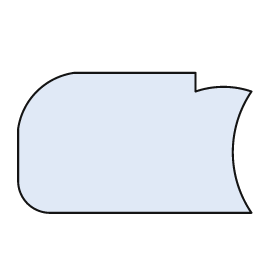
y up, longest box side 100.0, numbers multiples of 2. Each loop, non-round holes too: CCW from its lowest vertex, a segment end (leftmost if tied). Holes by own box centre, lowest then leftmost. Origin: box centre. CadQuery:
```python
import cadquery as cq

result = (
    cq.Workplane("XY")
    .moveTo(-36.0, -30.0)
    .lineTo(50.0, -30.0)
    .threePointArc((42.0, -4.0), (50.0, 22.0))
    .threePointArc((38.0, 24.0), (26.0, 22.0))
    .lineTo(26.0, 30.0)
    .lineTo(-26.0, 30.0)
    .threePointArc((-42.0, 22.0), (-50.0, 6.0))
    .lineTo(-50.0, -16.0)
    .threePointArc((-46.0, -26.0), (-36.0, -30.0))
    .close()
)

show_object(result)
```